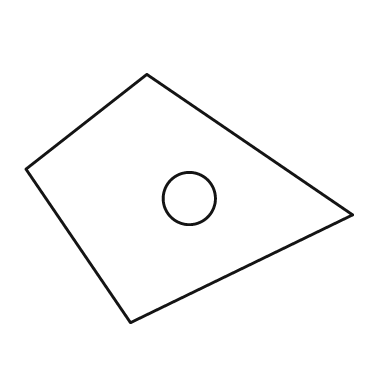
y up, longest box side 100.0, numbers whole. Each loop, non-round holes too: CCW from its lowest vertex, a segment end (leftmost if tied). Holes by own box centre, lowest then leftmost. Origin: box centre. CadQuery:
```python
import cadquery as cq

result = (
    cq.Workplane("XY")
    .moveTo(-18.0, -38.0)
    .lineTo(50.0, -5.0)
    .lineTo(-13.0, 38.0)
    .lineTo(-50.0, 9.0)
    .close()
    .moveTo(0.0, 0.0)
    .circle(8.0)
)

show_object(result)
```